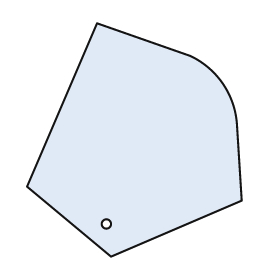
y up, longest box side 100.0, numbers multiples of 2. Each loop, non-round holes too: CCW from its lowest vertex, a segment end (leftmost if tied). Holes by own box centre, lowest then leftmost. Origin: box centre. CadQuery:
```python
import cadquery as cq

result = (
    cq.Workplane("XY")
    .moveTo(-10.0, -50.0)
    .lineTo(46.0, -26.0)
    .lineTo(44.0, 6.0)
    .threePointArc((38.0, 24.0), (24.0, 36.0))
    .lineTo(-16.0, 50.0)
    .lineTo(-46.0, -20.0)
    .close()
    .moveTo(-12.0, -36.0)
    .circle(2.0)
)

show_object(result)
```